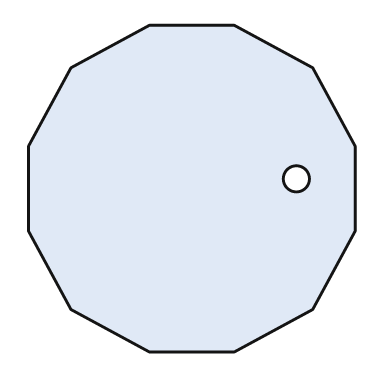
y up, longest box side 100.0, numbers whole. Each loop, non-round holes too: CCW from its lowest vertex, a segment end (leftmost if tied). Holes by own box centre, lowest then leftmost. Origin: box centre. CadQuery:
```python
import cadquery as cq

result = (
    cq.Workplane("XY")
    .moveTo(-13.0, -50.0)
    .lineTo(13.0, -50.0)
    .lineTo(37.0, -37.0)
    .lineTo(50.0, -13.0)
    .lineTo(50.0, 13.0)
    .lineTo(37.0, 37.0)
    .lineTo(13.0, 50.0)
    .lineTo(-13.0, 50.0)
    .lineTo(-37.0, 37.0)
    .lineTo(-50.0, 13.0)
    .lineTo(-50.0, -13.0)
    .lineTo(-37.0, -37.0)
    .close()
    .moveTo(32.0, 3.0)
    .circle(4.0)
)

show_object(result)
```